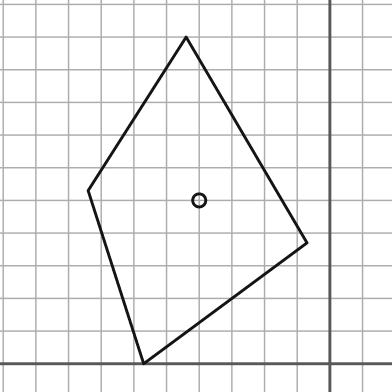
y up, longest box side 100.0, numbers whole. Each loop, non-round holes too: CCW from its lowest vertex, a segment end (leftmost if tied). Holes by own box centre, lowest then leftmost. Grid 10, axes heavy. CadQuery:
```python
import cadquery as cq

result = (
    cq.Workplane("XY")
    .moveTo(-57.0, 0.0)
    .lineTo(-7.0, 37.0)
    .lineTo(-44.0, 100.0)
    .lineTo(-74.0, 53.0)
    .close()
    .moveTo(-40.0, 50.0)
    .circle(2.0)
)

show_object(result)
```